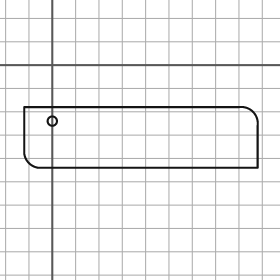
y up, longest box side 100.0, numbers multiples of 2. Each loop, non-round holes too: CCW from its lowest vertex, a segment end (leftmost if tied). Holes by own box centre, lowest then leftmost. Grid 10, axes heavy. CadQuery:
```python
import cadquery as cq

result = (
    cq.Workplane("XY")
    .moveTo(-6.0, -44.0)
    .lineTo(88.0, -44.0)
    .lineTo(88.0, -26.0)
    .threePointArc((86.0, -20.0), (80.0, -18.0))
    .lineTo(-12.0, -18.0)
    .lineTo(-12.0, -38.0)
    .threePointArc((-10.0, -42.0), (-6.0, -44.0))
    .close()
    .moveTo(0.0, -24.0)
    .circle(2.0)
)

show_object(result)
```